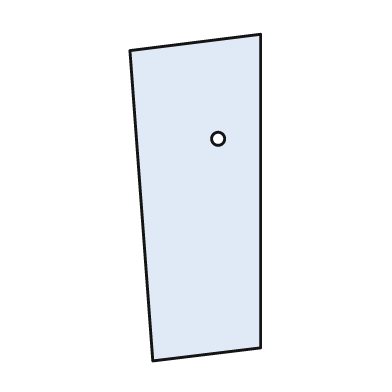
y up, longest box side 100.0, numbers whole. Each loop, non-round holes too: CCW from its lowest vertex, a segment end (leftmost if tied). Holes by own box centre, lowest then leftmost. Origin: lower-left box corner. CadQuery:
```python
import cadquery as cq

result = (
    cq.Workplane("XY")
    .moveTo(7.0, 0.0)
    .lineTo(40.0, 4.0)
    .lineTo(40.0, 100.0)
    .lineTo(0.0, 95.0)
    .close()
    .moveTo(27.0, 68.0)
    .circle(2.0)
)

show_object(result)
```